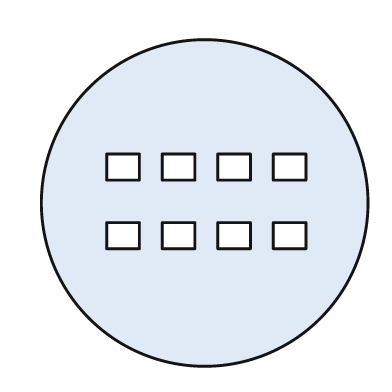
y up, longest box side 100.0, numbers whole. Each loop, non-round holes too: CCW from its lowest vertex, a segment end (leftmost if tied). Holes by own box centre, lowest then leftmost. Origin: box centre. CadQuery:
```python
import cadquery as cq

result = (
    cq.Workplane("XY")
    .moveTo(0.0, 0.0)
    .circle(50.0)
    .moveTo(-30.0, -14.0)
    .lineTo(-20.0, -14.0)
    .lineTo(-20.0, -6.0)
    .lineTo(-30.0, -6.0)
    .close()
    .moveTo(-13.0, -14.0)
    .lineTo(-3.0, -14.0)
    .lineTo(-3.0, -6.0)
    .lineTo(-13.0, -6.0)
    .close()
    .moveTo(4.0, -14.0)
    .lineTo(14.0, -14.0)
    .lineTo(14.0, -6.0)
    .lineTo(4.0, -6.0)
    .close()
    .moveTo(21.0, -14.0)
    .lineTo(31.0, -14.0)
    .lineTo(31.0, -6.0)
    .lineTo(21.0, -6.0)
    .close()
    .moveTo(-30.0, 7.0)
    .lineTo(-20.0, 7.0)
    .lineTo(-20.0, 15.0)
    .lineTo(-30.0, 15.0)
    .close()
    .moveTo(-13.0, 7.0)
    .lineTo(-3.0, 7.0)
    .lineTo(-3.0, 15.0)
    .lineTo(-13.0, 15.0)
    .close()
    .moveTo(4.0, 7.0)
    .lineTo(14.0, 7.0)
    .lineTo(14.0, 15.0)
    .lineTo(4.0, 15.0)
    .close()
    .moveTo(21.0, 7.0)
    .lineTo(31.0, 7.0)
    .lineTo(31.0, 15.0)
    .lineTo(21.0, 15.0)
    .close()
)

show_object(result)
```